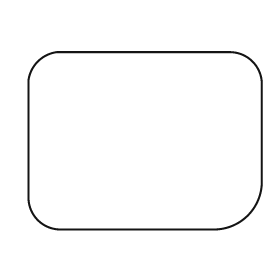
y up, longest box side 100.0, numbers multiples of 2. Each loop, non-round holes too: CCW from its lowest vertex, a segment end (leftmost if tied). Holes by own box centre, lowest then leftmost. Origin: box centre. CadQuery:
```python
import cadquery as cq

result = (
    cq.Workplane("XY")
    .moveTo(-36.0, -38.0)
    .lineTo(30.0, -38.0)
    .threePointArc((44.0, -32.0), (50.0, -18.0))
    .lineTo(50.0, 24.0)
    .threePointArc((46.0, 34.0), (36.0, 38.0))
    .lineTo(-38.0, 38.0)
    .threePointArc((-46.0, 34.0), (-50.0, 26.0))
    .lineTo(-50.0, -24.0)
    .threePointArc((-46.0, -34.0), (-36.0, -38.0))
    .close()
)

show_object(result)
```